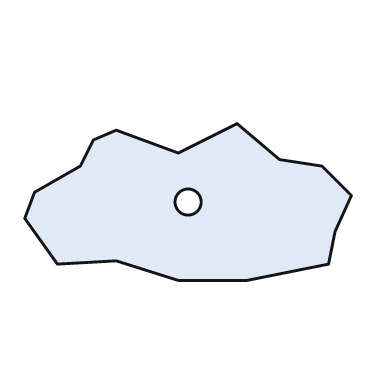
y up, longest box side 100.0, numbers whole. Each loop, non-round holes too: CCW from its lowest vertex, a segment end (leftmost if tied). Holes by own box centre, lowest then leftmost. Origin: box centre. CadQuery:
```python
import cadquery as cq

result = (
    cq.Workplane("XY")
    .moveTo(-3.0, -24.0)
    .lineTo(18.0, -24.0)
    .lineTo(43.0, -19.0)
    .lineTo(45.0, -9.0)
    .lineTo(50.0, 2.0)
    .lineTo(41.0, 11.0)
    .lineTo(28.0, 13.0)
    .lineTo(15.0, 24.0)
    .lineTo(-3.0, 15.0)
    .lineTo(-22.0, 22.0)
    .lineTo(-29.0, 19.0)
    .lineTo(-33.0, 11.0)
    .lineTo(-47.0, 3.0)
    .lineTo(-50.0, -5.0)
    .lineTo(-40.0, -19.0)
    .lineTo(-22.0, -18.0)
    .close()
    .moveTo(0.0, 0.0)
    .circle(4.0)
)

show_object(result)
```